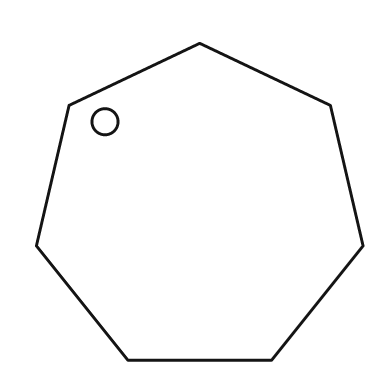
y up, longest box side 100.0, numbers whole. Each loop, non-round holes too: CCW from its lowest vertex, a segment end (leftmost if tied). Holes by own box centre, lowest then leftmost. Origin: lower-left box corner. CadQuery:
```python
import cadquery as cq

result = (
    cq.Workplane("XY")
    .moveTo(28.0, 0.0)
    .lineTo(72.0, 0.0)
    .lineTo(100.0, 35.0)
    .lineTo(90.0, 78.0)
    .lineTo(50.0, 97.0)
    .lineTo(10.0, 78.0)
    .lineTo(0.0, 35.0)
    .close()
    .moveTo(21.0, 73.0)
    .circle(4.0)
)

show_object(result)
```